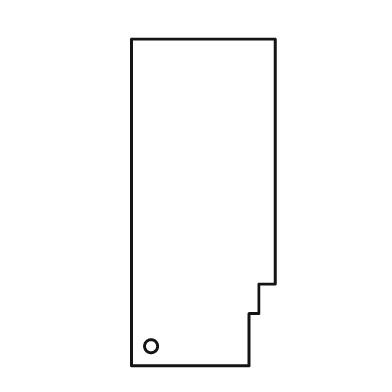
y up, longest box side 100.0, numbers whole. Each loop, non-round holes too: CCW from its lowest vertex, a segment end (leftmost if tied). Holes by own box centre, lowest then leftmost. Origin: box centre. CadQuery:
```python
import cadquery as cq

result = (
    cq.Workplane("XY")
    .moveTo(-22.0, -50.0)
    .lineTo(14.0, -50.0)
    .lineTo(14.0, -34.0)
    .lineTo(17.0, -34.0)
    .lineTo(17.0, -25.0)
    .lineTo(22.0, -25.0)
    .lineTo(22.0, 50.0)
    .lineTo(-22.0, 50.0)
    .close()
    .moveTo(-16.0, -44.0)
    .circle(2.0)
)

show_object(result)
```